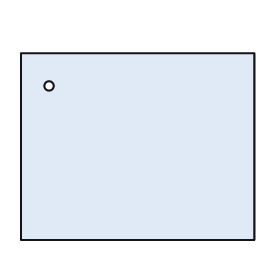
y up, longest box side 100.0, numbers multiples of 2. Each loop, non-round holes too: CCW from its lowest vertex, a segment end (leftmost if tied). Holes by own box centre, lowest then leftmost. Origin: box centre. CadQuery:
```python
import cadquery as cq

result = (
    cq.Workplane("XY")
    .moveTo(-50.0, -40.0)
    .lineTo(50.0, -40.0)
    .lineTo(50.0, 40.0)
    .lineTo(-50.0, 40.0)
    .close()
    .moveTo(-38.0, 26.0)
    .circle(2.0)
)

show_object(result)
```